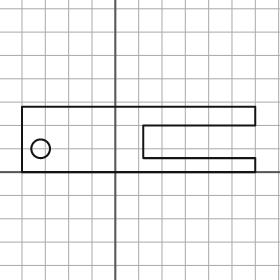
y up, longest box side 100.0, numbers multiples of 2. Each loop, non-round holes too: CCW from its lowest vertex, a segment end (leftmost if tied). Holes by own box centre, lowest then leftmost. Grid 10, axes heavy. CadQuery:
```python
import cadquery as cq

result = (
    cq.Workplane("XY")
    .moveTo(-40.0, 0.0)
    .lineTo(60.0, 0.0)
    .lineTo(60.0, 6.0)
    .lineTo(12.0, 6.0)
    .lineTo(12.0, 20.0)
    .lineTo(60.0, 20.0)
    .lineTo(60.0, 28.0)
    .lineTo(-40.0, 28.0)
    .close()
    .moveTo(-32.0, 10.0)
    .circle(4.0)
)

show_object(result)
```